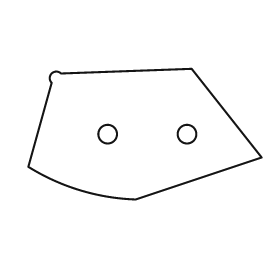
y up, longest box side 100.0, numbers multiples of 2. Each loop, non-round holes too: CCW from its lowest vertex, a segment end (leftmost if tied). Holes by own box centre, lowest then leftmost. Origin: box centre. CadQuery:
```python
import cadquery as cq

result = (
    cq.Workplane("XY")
    .moveTo(-4.0, -28.0)
    .lineTo(50.0, -10.0)
    .lineTo(20.0, 28.0)
    .lineTo(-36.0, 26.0)
    .threePointArc((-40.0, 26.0), (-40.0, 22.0))
    .lineTo(-50.0, -14.0)
    .threePointArc((-28.0, -24.0), (-4.0, -28.0))
    .close()
    .moveTo(-16.0, 0.0)
    .circle(4.0)
    .moveTo(18.0, 0.0)
    .circle(4.0)
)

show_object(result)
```